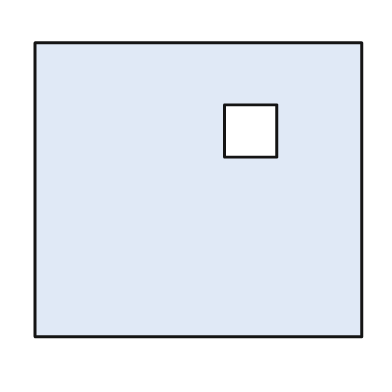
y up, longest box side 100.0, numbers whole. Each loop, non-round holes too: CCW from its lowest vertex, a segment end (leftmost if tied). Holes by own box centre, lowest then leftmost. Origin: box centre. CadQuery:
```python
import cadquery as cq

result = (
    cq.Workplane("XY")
    .moveTo(-50.0, -45.0)
    .lineTo(50.0, -45.0)
    .lineTo(50.0, 45.0)
    .lineTo(-50.0, 45.0)
    .close()
    .moveTo(8.0, 10.0)
    .lineTo(24.0, 10.0)
    .lineTo(24.0, 26.0)
    .lineTo(8.0, 26.0)
    .close()
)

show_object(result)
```